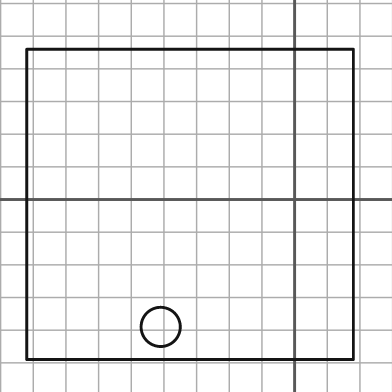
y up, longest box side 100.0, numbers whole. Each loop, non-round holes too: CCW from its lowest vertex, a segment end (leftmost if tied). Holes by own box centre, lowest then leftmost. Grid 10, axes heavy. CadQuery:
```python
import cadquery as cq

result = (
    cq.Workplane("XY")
    .moveTo(-82.0, -49.0)
    .lineTo(18.0, -49.0)
    .lineTo(18.0, 46.0)
    .lineTo(-82.0, 46.0)
    .close()
    .moveTo(-41.0, -39.0)
    .circle(6.0)
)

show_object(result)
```